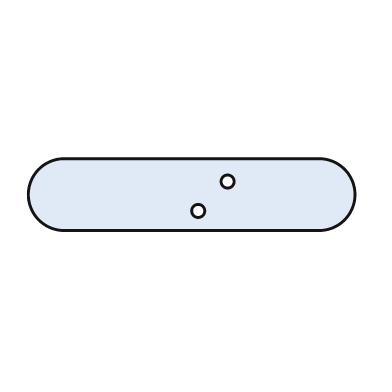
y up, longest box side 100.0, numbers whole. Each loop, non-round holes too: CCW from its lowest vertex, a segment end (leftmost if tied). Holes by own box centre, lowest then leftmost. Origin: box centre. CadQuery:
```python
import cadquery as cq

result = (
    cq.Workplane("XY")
    .moveTo(-39.0, -11.0)
    .lineTo(39.0, -11.0)
    .threePointArc((50.0, 0.0), (39.0, 11.0))
    .lineTo(-39.0, 11.0)
    .threePointArc((-50.0, 0.0), (-39.0, -11.0))
    .close()
    .moveTo(2.0, -5.0)
    .circle(2.0)
    .moveTo(11.0, 4.0)
    .circle(2.0)
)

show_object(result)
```